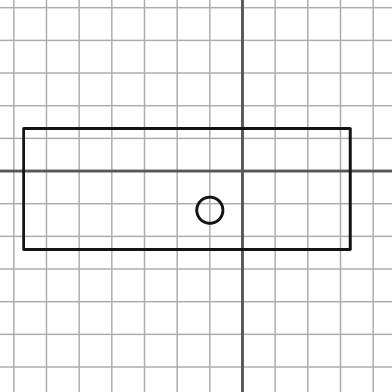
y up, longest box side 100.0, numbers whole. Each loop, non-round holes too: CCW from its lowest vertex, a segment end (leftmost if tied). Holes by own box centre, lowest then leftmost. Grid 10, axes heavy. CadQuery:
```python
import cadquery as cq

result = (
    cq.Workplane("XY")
    .moveTo(-67.0, -24.0)
    .lineTo(33.0, -24.0)
    .lineTo(33.0, 13.0)
    .lineTo(-67.0, 13.0)
    .close()
    .moveTo(-10.0, -12.0)
    .circle(4.0)
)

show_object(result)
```